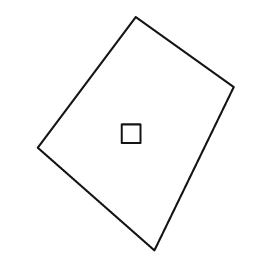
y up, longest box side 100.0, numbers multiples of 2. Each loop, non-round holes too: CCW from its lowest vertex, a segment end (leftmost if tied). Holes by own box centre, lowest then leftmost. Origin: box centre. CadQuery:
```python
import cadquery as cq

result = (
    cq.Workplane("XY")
    .moveTo(8.0, -50.0)
    .lineTo(42.0, 20.0)
    .lineTo(0.0, 50.0)
    .lineTo(-42.0, -6.0)
    .close()
    .moveTo(-6.0, -4.0)
    .lineTo(2.0, -4.0)
    .lineTo(2.0, 4.0)
    .lineTo(-6.0, 4.0)
    .close()
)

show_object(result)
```